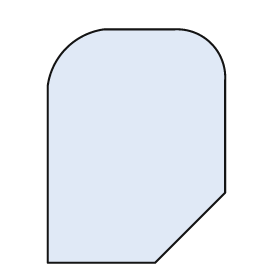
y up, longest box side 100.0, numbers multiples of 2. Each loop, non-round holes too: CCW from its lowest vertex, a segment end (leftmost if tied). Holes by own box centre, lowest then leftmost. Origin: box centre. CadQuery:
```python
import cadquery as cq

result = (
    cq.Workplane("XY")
    .moveTo(-38.0, -50.0)
    .lineTo(8.0, -50.0)
    .lineTo(38.0, -20.0)
    .lineTo(38.0, 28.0)
    .threePointArc((32.0, 44.0), (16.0, 50.0))
    .lineTo(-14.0, 50.0)
    .threePointArc((-30.0, 42.0), (-38.0, 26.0))
    .close()
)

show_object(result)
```